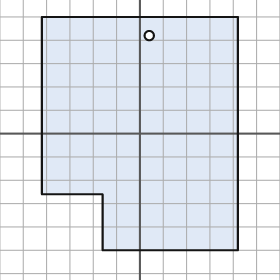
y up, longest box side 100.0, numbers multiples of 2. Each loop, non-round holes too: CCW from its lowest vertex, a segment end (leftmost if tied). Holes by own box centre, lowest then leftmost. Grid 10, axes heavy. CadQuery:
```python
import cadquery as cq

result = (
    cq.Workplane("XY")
    .moveTo(-16.0, -50.0)
    .lineTo(42.0, -50.0)
    .lineTo(42.0, 50.0)
    .lineTo(-42.0, 50.0)
    .lineTo(-42.0, -26.0)
    .lineTo(-16.0, -26.0)
    .close()
    .moveTo(4.0, 42.0)
    .circle(2.0)
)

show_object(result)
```